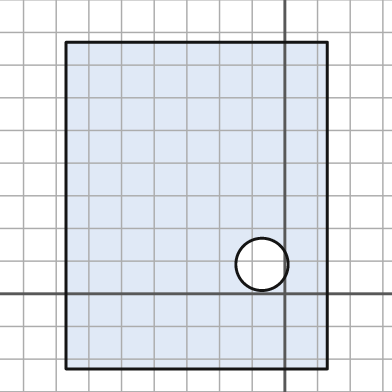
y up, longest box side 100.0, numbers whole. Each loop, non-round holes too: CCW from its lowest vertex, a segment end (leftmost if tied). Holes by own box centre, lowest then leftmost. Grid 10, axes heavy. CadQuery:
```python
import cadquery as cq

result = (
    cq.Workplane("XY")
    .moveTo(-67.0, -23.0)
    .lineTo(13.0, -23.0)
    .lineTo(13.0, 77.0)
    .lineTo(-67.0, 77.0)
    .close()
    .moveTo(-7.0, 9.0)
    .circle(8.0)
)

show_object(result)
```